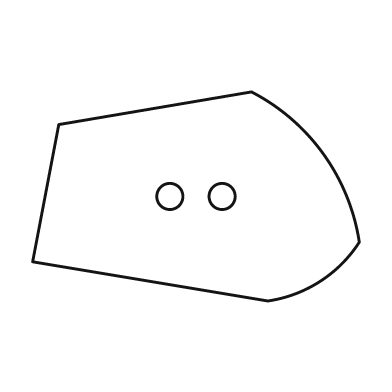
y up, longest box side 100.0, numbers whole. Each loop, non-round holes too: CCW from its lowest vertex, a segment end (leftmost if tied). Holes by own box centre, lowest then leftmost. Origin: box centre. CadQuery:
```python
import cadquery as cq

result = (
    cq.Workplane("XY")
    .moveTo(22.0, -32.0)
    .threePointArc((38.0, -26.0), (50.0, -14.0))
    .threePointArc((39.0, 13.0), (17.0, 32.0))
    .lineTo(-42.0, 22.0)
    .lineTo(-50.0, -20.0)
    .close()
    .moveTo(-8.0, 0.0)
    .circle(4.0)
    .moveTo(8.0, 0.0)
    .circle(4.0)
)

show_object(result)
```